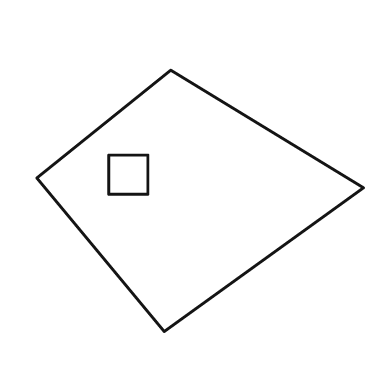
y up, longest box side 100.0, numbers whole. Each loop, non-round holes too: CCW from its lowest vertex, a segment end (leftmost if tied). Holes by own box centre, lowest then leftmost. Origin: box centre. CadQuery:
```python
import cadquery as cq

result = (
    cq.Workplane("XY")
    .moveTo(-11.0, -40.0)
    .lineTo(50.0, 4.0)
    .lineTo(-9.0, 40.0)
    .lineTo(-50.0, 7.0)
    .close()
    .moveTo(-28.0, 2.0)
    .lineTo(-16.0, 2.0)
    .lineTo(-16.0, 14.0)
    .lineTo(-28.0, 14.0)
    .close()
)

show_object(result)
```